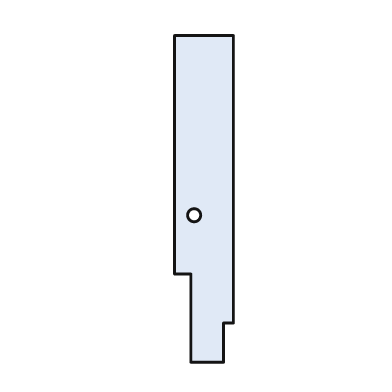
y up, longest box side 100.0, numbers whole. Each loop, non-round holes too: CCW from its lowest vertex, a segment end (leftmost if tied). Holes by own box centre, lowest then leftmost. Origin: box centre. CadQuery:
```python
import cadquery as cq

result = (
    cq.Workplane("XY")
    .moveTo(-4.0, -50.0)
    .lineTo(6.0, -50.0)
    .lineTo(6.0, -38.0)
    .lineTo(9.0, -38.0)
    .lineTo(9.0, 50.0)
    .lineTo(-9.0, 50.0)
    .lineTo(-9.0, -23.0)
    .lineTo(-4.0, -23.0)
    .close()
    .moveTo(-3.0, -5.0)
    .circle(2.0)
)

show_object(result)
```